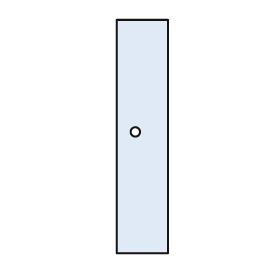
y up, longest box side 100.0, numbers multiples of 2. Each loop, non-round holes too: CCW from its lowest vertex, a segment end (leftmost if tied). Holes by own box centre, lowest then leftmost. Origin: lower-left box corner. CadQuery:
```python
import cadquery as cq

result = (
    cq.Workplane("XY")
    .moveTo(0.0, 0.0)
    .lineTo(22.0, 0.0)
    .lineTo(22.0, 100.0)
    .lineTo(0.0, 100.0)
    .close()
    .moveTo(8.0, 52.0)
    .circle(2.0)
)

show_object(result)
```